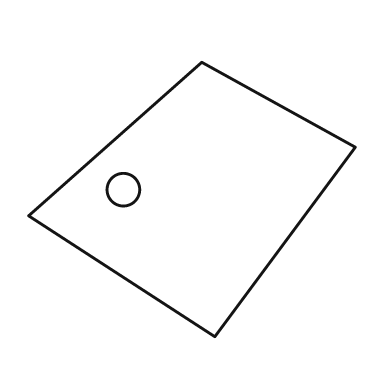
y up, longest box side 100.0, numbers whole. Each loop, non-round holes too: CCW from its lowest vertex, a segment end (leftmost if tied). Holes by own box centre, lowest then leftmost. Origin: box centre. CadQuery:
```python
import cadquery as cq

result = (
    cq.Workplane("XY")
    .moveTo(7.0, -42.0)
    .lineTo(50.0, 16.0)
    .lineTo(3.0, 42.0)
    .lineTo(-50.0, -5.0)
    .close()
    .moveTo(-21.0, 3.0)
    .circle(5.0)
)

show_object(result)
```